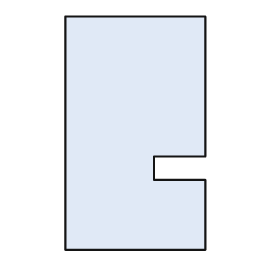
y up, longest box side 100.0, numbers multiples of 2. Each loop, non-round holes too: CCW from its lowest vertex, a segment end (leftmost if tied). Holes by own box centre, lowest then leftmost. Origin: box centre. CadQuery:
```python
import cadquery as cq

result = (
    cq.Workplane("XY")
    .moveTo(-30.0, -50.0)
    .lineTo(30.0, -50.0)
    .lineTo(30.0, -20.0)
    .lineTo(8.0, -20.0)
    .lineTo(8.0, -10.0)
    .lineTo(30.0, -10.0)
    .lineTo(30.0, 50.0)
    .lineTo(-30.0, 50.0)
    .close()
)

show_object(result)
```